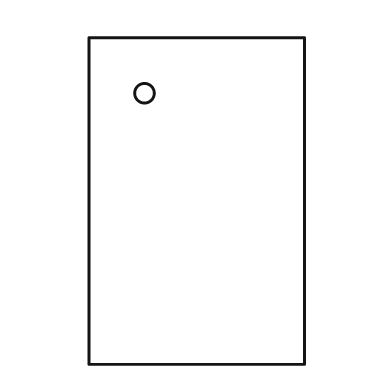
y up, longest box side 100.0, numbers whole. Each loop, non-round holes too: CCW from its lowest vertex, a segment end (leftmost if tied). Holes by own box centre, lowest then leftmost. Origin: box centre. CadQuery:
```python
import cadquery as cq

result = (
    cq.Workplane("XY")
    .moveTo(-33.0, -50.0)
    .lineTo(33.0, -50.0)
    .lineTo(33.0, 50.0)
    .lineTo(-33.0, 50.0)
    .close()
    .moveTo(-16.0, 33.0)
    .circle(3.0)
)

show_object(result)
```